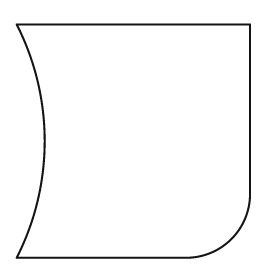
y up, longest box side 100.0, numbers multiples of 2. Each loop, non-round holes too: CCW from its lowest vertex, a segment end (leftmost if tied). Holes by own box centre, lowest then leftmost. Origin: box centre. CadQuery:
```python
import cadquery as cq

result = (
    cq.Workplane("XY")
    .moveTo(-50.0, -50.0)
    .lineTo(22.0, -50.0)
    .threePointArc((42.0, -42.0), (50.0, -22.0))
    .lineTo(50.0, 50.0)
    .lineTo(-50.0, 50.0)
    .threePointArc((-38.0, 0.0), (-50.0, -50.0))
    .close()
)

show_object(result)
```